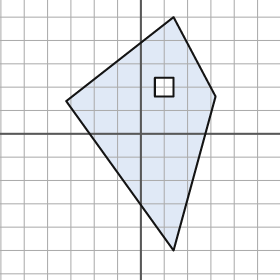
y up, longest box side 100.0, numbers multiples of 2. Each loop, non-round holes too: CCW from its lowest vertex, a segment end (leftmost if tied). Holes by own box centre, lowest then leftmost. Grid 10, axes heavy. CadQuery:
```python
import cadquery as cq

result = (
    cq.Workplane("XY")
    .moveTo(14.0, -50.0)
    .lineTo(32.0, 16.0)
    .lineTo(14.0, 50.0)
    .lineTo(-32.0, 14.0)
    .close()
    .moveTo(6.0, 16.0)
    .lineTo(14.0, 16.0)
    .lineTo(14.0, 24.0)
    .lineTo(6.0, 24.0)
    .close()
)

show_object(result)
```